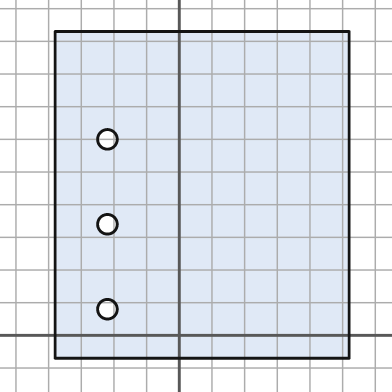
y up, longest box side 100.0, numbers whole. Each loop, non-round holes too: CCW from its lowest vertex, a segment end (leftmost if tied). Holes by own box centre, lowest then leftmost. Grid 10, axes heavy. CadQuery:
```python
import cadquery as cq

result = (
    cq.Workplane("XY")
    .moveTo(-38.0, -7.0)
    .lineTo(52.0, -7.0)
    .lineTo(52.0, 93.0)
    .lineTo(-38.0, 93.0)
    .close()
    .moveTo(-22.0, 8.0)
    .circle(3.0)
    .moveTo(-22.0, 34.0)
    .circle(3.0)
    .moveTo(-22.0, 60.0)
    .circle(3.0)
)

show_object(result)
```